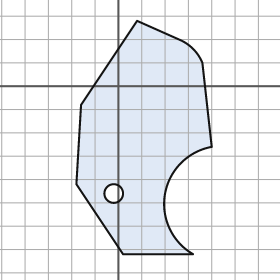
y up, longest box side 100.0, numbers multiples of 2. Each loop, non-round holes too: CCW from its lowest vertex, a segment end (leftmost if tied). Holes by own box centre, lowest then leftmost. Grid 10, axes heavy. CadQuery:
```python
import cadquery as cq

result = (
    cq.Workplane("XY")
    .moveTo(2.0, -72.0)
    .lineTo(32.0, -72.0)
    .threePointArc((20.0, -46.0), (40.0, -26.0))
    .lineTo(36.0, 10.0)
    .threePointArc((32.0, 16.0), (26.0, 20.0))
    .lineTo(8.0, 28.0)
    .lineTo(-16.0, -8.0)
    .lineTo(-18.0, -42.0)
    .close()
    .moveTo(-2.0, -46.0)
    .circle(4.0)
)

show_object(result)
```